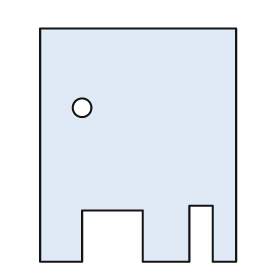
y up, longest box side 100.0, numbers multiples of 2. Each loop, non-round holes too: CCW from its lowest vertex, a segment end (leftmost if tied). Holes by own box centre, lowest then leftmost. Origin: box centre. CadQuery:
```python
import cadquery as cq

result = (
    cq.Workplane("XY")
    .moveTo(-42.0, -50.0)
    .lineTo(-24.0, -50.0)
    .lineTo(-24.0, -28.0)
    .lineTo(2.0, -28.0)
    .lineTo(2.0, -50.0)
    .lineTo(22.0, -50.0)
    .lineTo(22.0, -26.0)
    .lineTo(32.0, -26.0)
    .lineTo(32.0, -50.0)
    .lineTo(42.0, -50.0)
    .lineTo(42.0, 50.0)
    .lineTo(-42.0, 50.0)
    .close()
    .moveTo(-24.0, 16.0)
    .circle(4.0)
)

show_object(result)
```